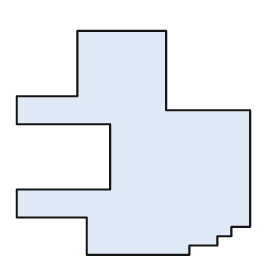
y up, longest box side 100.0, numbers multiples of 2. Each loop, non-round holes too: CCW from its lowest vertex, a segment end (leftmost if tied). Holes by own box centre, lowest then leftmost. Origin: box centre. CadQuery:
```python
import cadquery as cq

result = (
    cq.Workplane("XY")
    .moveTo(-20.0, -48.0)
    .lineTo(24.0, -48.0)
    .lineTo(24.0, -44.0)
    .lineTo(36.0, -44.0)
    .lineTo(36.0, -40.0)
    .lineTo(42.0, -40.0)
    .lineTo(42.0, -36.0)
    .lineTo(50.0, -36.0)
    .lineTo(50.0, 14.0)
    .lineTo(14.0, 14.0)
    .lineTo(14.0, 48.0)
    .lineTo(-24.0, 48.0)
    .lineTo(-24.0, 20.0)
    .lineTo(-50.0, 20.0)
    .lineTo(-50.0, 8.0)
    .lineTo(-10.0, 8.0)
    .lineTo(-10.0, -20.0)
    .lineTo(-50.0, -20.0)
    .lineTo(-50.0, -32.0)
    .lineTo(-20.0, -32.0)
    .close()
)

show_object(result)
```